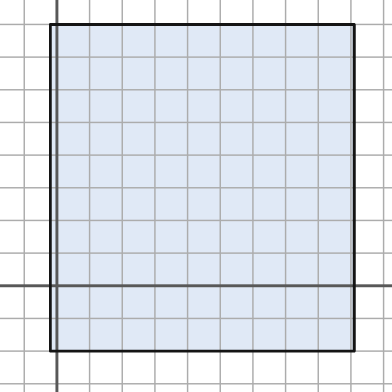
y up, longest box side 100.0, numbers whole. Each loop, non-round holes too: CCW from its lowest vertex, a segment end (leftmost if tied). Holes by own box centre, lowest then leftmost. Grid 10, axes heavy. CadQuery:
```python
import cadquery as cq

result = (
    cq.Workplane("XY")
    .moveTo(-2.0, -20.0)
    .lineTo(91.0, -20.0)
    .lineTo(91.0, 80.0)
    .lineTo(-2.0, 80.0)
    .close()
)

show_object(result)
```